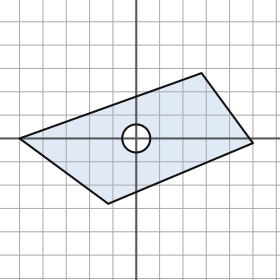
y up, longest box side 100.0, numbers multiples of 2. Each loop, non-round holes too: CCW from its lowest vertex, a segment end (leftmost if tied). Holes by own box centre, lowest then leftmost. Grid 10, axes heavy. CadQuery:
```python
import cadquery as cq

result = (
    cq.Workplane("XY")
    .moveTo(-12.0, -28.0)
    .lineTo(50.0, -2.0)
    .lineTo(28.0, 28.0)
    .lineTo(-50.0, 0.0)
    .close()
    .moveTo(0.0, 0.0)
    .circle(6.0)
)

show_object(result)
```